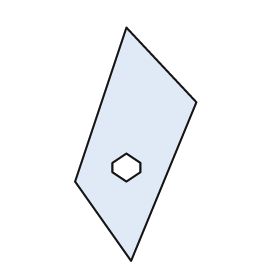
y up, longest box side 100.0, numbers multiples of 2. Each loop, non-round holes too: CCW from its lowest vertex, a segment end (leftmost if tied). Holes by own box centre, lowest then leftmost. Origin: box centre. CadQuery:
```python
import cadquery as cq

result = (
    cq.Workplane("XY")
    .moveTo(-2.0, -50.0)
    .lineTo(26.0, 18.0)
    .lineTo(-4.0, 50.0)
    .lineTo(-26.0, -16.0)
    .close()
    .moveTo(-4.0, -16.0)
    .lineTo(2.0, -12.0)
    .lineTo(2.0, -8.0)
    .lineTo(-4.0, -4.0)
    .lineTo(-10.0, -8.0)
    .lineTo(-10.0, -12.0)
    .close()
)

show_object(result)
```